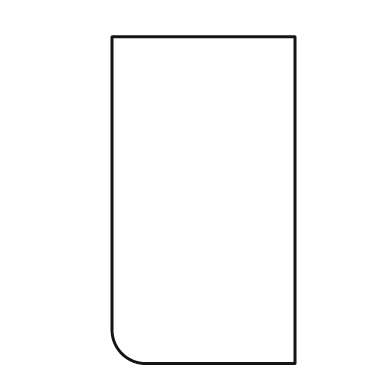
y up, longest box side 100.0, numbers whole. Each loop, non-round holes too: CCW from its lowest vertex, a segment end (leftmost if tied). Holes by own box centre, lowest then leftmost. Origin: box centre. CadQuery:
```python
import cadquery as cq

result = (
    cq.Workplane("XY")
    .moveTo(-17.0, -50.0)
    .lineTo(28.0, -50.0)
    .lineTo(28.0, 50.0)
    .lineTo(-28.0, 50.0)
    .lineTo(-28.0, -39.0)
    .threePointArc((-25.0, -47.0), (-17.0, -50.0))
    .close()
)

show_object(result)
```